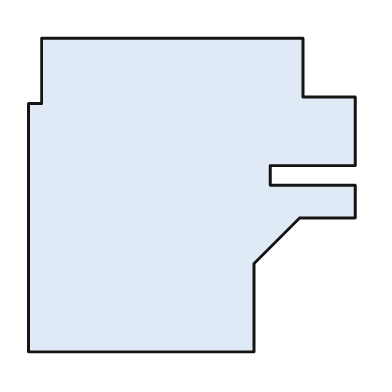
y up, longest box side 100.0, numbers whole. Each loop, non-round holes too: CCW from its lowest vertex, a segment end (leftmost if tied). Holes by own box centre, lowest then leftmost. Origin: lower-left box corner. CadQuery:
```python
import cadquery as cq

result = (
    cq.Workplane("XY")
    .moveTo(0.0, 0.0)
    .lineTo(69.0, 0.0)
    .lineTo(69.0, 27.0)
    .lineTo(83.0, 41.0)
    .lineTo(100.0, 41.0)
    .lineTo(100.0, 51.0)
    .lineTo(74.0, 51.0)
    .lineTo(74.0, 57.0)
    .lineTo(100.0, 57.0)
    .lineTo(100.0, 78.0)
    .lineTo(84.0, 78.0)
    .lineTo(84.0, 96.0)
    .lineTo(4.0, 96.0)
    .lineTo(4.0, 76.0)
    .lineTo(0.0, 76.0)
    .close()
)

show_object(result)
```